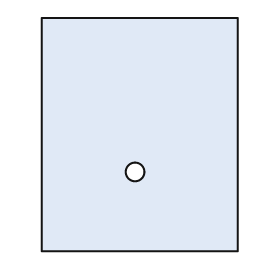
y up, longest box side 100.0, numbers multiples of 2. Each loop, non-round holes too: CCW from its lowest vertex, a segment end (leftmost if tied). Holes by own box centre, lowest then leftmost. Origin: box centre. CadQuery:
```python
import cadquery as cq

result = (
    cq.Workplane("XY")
    .moveTo(-42.0, -50.0)
    .lineTo(42.0, -50.0)
    .lineTo(42.0, 50.0)
    .lineTo(-42.0, 50.0)
    .close()
    .moveTo(-2.0, -16.0)
    .circle(4.0)
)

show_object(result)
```